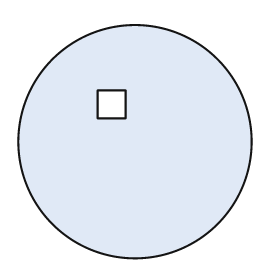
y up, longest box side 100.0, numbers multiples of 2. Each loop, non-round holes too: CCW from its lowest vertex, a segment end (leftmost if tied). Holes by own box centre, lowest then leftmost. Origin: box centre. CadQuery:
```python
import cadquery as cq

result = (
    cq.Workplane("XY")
    .moveTo(0.0, 0.0)
    .circle(50.0)
    .moveTo(-16.0, 10.0)
    .lineTo(-4.0, 10.0)
    .lineTo(-4.0, 22.0)
    .lineTo(-16.0, 22.0)
    .close()
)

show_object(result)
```